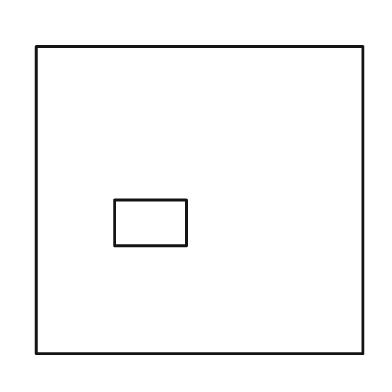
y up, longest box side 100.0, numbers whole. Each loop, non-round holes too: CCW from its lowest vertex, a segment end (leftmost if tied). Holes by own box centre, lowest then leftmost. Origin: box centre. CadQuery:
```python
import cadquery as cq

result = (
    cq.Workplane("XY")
    .moveTo(-50.0, -47.0)
    .lineTo(50.0, -47.0)
    .lineTo(50.0, 47.0)
    .lineTo(-50.0, 47.0)
    .close()
    .moveTo(-26.0, -14.0)
    .lineTo(-4.0, -14.0)
    .lineTo(-4.0, 0.0)
    .lineTo(-26.0, 0.0)
    .close()
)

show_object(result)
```